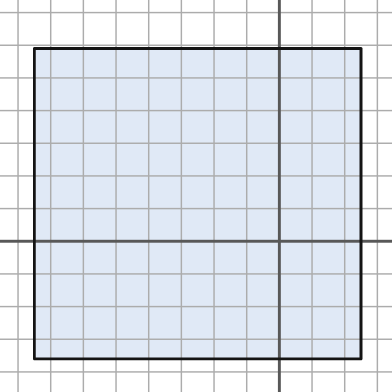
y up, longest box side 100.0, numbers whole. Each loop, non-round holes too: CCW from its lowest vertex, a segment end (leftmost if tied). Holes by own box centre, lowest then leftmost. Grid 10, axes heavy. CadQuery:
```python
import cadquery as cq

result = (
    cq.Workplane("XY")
    .moveTo(-75.0, -36.0)
    .lineTo(25.0, -36.0)
    .lineTo(25.0, 59.0)
    .lineTo(-75.0, 59.0)
    .close()
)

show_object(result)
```